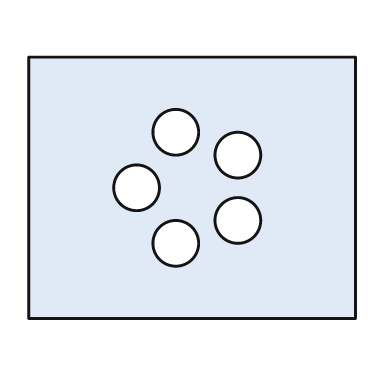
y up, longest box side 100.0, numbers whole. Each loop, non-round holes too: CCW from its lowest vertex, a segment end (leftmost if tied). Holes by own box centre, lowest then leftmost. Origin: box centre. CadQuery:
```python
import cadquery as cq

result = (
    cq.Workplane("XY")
    .moveTo(-50.0, -40.0)
    .lineTo(50.0, -40.0)
    .lineTo(50.0, 40.0)
    .lineTo(-50.0, 40.0)
    .close()
    .moveTo(-5.0, -17.0)
    .circle(7.0)
    .moveTo(14.0, -10.0)
    .circle(7.0)
    .moveTo(-17.0, 0.0)
    .circle(7.0)
    .moveTo(14.0, 10.0)
    .circle(7.0)
    .moveTo(-5.0, 17.0)
    .circle(7.0)
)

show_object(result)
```